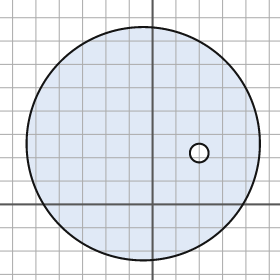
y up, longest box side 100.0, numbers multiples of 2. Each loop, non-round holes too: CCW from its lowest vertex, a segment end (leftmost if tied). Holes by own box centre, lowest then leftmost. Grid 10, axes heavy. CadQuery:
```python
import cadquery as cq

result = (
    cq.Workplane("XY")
    .moveTo(-4.0, 26.0)
    .circle(50.0)
    .moveTo(20.0, 22.0)
    .circle(4.0)
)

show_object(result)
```